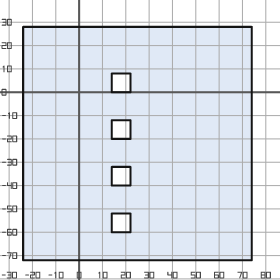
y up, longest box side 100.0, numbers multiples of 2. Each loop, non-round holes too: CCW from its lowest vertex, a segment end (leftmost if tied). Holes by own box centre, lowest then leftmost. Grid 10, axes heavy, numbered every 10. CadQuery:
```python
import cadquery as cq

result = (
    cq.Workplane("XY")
    .moveTo(-24.0, -72.0)
    .lineTo(74.0, -72.0)
    .lineTo(74.0, 28.0)
    .lineTo(-24.0, 28.0)
    .close()
    .moveTo(14.0, -60.0)
    .lineTo(22.0, -60.0)
    .lineTo(22.0, -52.0)
    .lineTo(14.0, -52.0)
    .close()
    .moveTo(14.0, -40.0)
    .lineTo(22.0, -40.0)
    .lineTo(22.0, -32.0)
    .lineTo(14.0, -32.0)
    .close()
    .moveTo(14.0, -20.0)
    .lineTo(22.0, -20.0)
    .lineTo(22.0, -12.0)
    .lineTo(14.0, -12.0)
    .close()
    .moveTo(14.0, 0.0)
    .lineTo(22.0, 0.0)
    .lineTo(22.0, 8.0)
    .lineTo(14.0, 8.0)
    .close()
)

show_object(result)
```